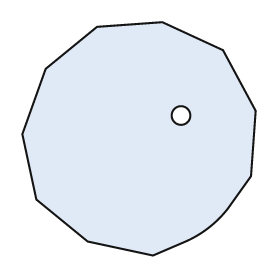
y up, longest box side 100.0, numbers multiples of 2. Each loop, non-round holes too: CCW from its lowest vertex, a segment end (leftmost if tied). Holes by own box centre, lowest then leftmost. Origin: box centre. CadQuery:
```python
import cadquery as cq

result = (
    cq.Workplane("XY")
    .moveTo(6.0, -50.0)
    .lineTo(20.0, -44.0)
    .threePointArc((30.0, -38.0), (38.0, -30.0))
    .lineTo(48.0, -16.0)
    .lineTo(50.0, 12.0)
    .lineTo(36.0, 38.0)
    .lineTo(10.0, 50.0)
    .lineTo(-18.0, 48.0)
    .lineTo(-40.0, 30.0)
    .lineTo(-50.0, 2.0)
    .lineTo(-44.0, -26.0)
    .lineTo(-22.0, -44.0)
    .close()
    .moveTo(18.0, 10.0)
    .circle(4.0)
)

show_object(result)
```